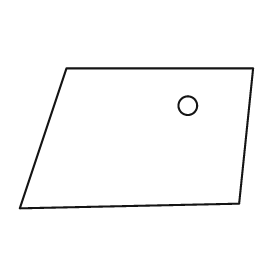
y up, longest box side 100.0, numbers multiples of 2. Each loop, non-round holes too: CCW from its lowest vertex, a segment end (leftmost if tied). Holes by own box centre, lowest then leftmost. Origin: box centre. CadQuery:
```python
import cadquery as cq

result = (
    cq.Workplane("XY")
    .moveTo(-50.0, -30.0)
    .lineTo(44.0, -28.0)
    .lineTo(50.0, 30.0)
    .lineTo(-30.0, 30.0)
    .close()
    .moveTo(22.0, 14.0)
    .circle(4.0)
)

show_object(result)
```